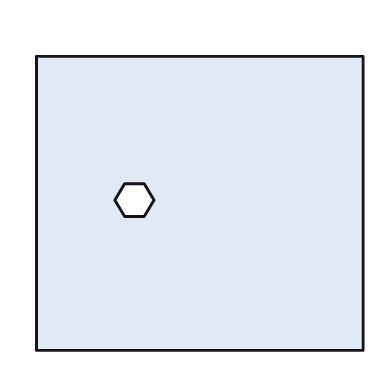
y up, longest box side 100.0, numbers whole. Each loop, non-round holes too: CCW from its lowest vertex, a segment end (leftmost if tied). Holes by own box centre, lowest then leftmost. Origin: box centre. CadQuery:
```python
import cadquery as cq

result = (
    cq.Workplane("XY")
    .moveTo(-50.0, -45.0)
    .lineTo(50.0, -45.0)
    .lineTo(50.0, 45.0)
    .lineTo(-50.0, 45.0)
    .close()
    .moveTo(-23.0, -4.0)
    .lineTo(-17.0, -4.0)
    .lineTo(-14.0, 1.0)
    .lineTo(-17.0, 6.0)
    .lineTo(-23.0, 6.0)
    .lineTo(-26.0, 1.0)
    .close()
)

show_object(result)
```